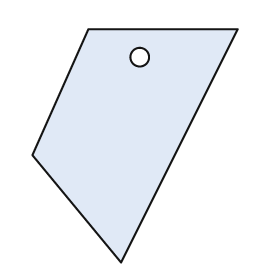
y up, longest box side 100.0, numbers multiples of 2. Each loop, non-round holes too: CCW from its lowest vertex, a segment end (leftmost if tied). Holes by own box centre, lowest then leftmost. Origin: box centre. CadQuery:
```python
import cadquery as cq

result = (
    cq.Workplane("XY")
    .moveTo(-6.0, -50.0)
    .lineTo(44.0, 50.0)
    .lineTo(-20.0, 50.0)
    .lineTo(-44.0, -4.0)
    .close()
    .moveTo(2.0, 38.0)
    .circle(4.0)
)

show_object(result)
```